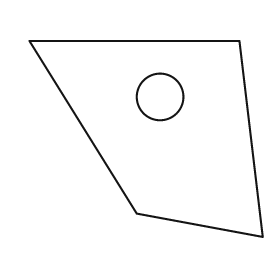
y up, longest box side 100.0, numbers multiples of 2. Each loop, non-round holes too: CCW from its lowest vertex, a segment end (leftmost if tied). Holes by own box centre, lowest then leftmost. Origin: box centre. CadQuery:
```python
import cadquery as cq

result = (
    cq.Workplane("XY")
    .moveTo(50.0, -42.0)
    .lineTo(40.0, 42.0)
    .lineTo(-50.0, 42.0)
    .lineTo(-4.0, -32.0)
    .close()
    .moveTo(6.0, 18.0)
    .circle(10.0)
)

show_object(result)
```